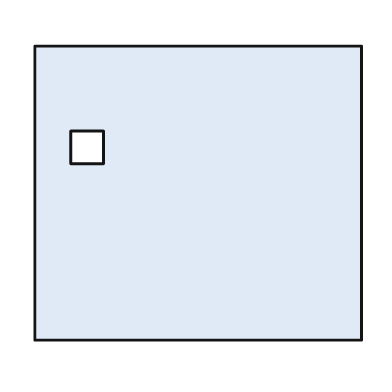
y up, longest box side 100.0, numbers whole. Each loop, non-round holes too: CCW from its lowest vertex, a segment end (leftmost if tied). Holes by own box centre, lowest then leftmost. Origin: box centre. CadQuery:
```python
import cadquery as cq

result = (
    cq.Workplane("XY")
    .moveTo(-50.0, -45.0)
    .lineTo(50.0, -45.0)
    .lineTo(50.0, 45.0)
    .lineTo(-50.0, 45.0)
    .close()
    .moveTo(-39.0, 9.0)
    .lineTo(-29.0, 9.0)
    .lineTo(-29.0, 19.0)
    .lineTo(-39.0, 19.0)
    .close()
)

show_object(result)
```